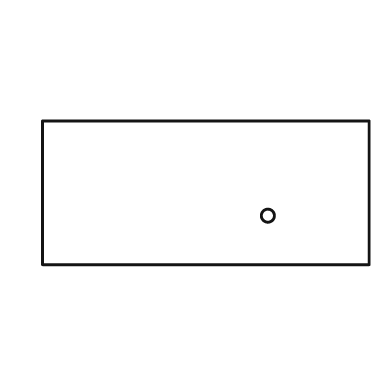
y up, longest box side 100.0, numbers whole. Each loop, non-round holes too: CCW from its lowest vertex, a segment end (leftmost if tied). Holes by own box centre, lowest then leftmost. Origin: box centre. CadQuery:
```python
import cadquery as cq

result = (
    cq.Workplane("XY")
    .moveTo(-50.0, -22.0)
    .lineTo(50.0, -22.0)
    .lineTo(50.0, 22.0)
    .lineTo(-50.0, 22.0)
    .close()
    .moveTo(19.0, -7.0)
    .circle(2.0)
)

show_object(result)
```